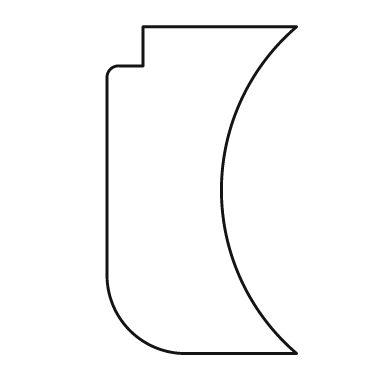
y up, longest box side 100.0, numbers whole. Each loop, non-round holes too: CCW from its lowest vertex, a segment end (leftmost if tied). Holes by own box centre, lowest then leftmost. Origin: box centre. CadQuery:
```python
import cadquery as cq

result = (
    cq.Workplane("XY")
    .moveTo(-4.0, -50.0)
    .lineTo(29.0, -50.0)
    .threePointArc((6.0, 0.0), (29.0, 50.0))
    .lineTo(-18.0, 50.0)
    .lineTo(-18.0, 38.0)
    .lineTo(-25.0, 38.0)
    .threePointArc((-28.0, 37.0), (-29.0, 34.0))
    .lineTo(-29.0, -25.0)
    .threePointArc((-22.0, -43.0), (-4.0, -50.0))
    .close()
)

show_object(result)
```